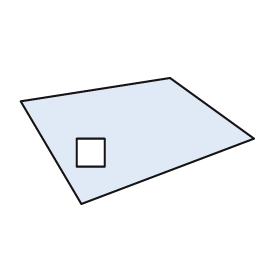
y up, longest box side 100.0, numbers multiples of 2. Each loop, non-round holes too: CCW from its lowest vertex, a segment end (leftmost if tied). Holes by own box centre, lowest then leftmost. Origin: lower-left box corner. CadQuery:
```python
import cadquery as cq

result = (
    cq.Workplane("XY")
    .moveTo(26.0, 0.0)
    .lineTo(100.0, 28.0)
    .lineTo(64.0, 54.0)
    .lineTo(0.0, 44.0)
    .close()
    .moveTo(24.0, 16.0)
    .lineTo(36.0, 16.0)
    .lineTo(36.0, 28.0)
    .lineTo(24.0, 28.0)
    .close()
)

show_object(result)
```